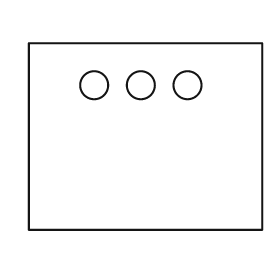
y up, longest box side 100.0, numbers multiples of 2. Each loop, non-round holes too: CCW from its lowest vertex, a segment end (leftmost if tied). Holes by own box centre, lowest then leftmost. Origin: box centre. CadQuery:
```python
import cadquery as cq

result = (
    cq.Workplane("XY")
    .moveTo(-50.0, -40.0)
    .lineTo(50.0, -40.0)
    .lineTo(50.0, 40.0)
    .lineTo(-50.0, 40.0)
    .close()
    .moveTo(-22.0, 22.0)
    .circle(6.0)
    .moveTo(-2.0, 22.0)
    .circle(6.0)
    .moveTo(18.0, 22.0)
    .circle(6.0)
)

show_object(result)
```